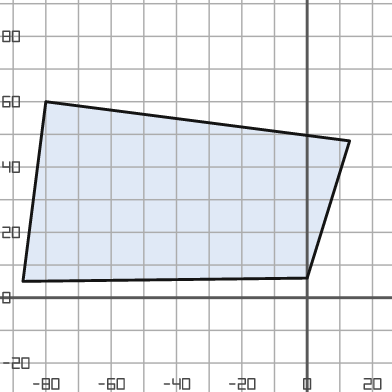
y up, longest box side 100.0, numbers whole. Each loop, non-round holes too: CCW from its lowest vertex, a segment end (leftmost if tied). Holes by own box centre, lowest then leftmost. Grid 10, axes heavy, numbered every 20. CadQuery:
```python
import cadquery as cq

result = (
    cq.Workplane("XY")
    .moveTo(-87.0, 5.0)
    .lineTo(0.0, 6.0)
    .lineTo(13.0, 48.0)
    .lineTo(-80.0, 60.0)
    .close()
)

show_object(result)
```